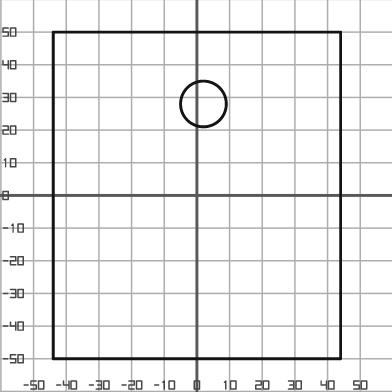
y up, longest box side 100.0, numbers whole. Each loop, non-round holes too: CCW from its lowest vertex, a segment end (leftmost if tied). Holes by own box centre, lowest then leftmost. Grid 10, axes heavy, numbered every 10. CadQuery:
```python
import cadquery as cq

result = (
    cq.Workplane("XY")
    .moveTo(-44.0, -50.0)
    .lineTo(44.0, -50.0)
    .lineTo(44.0, 50.0)
    .lineTo(-44.0, 50.0)
    .close()
    .moveTo(2.0, 28.0)
    .circle(7.0)
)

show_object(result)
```